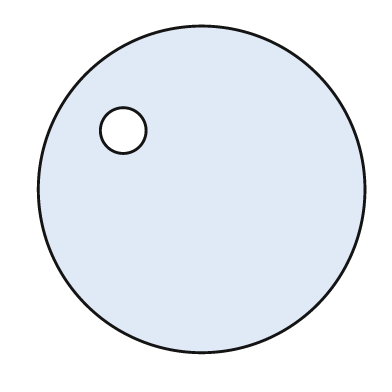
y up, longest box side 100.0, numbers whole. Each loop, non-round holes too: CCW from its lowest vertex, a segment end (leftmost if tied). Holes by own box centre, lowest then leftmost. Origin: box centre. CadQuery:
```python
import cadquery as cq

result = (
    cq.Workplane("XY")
    .moveTo(0.0, 0.0)
    .circle(50.0)
    .moveTo(-24.0, 18.0)
    .circle(7.0)
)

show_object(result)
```